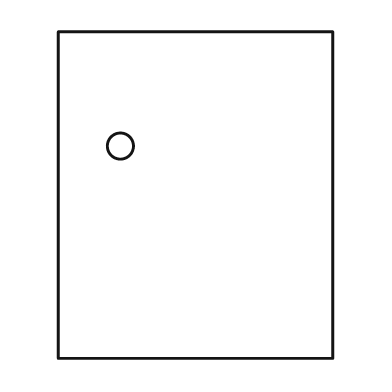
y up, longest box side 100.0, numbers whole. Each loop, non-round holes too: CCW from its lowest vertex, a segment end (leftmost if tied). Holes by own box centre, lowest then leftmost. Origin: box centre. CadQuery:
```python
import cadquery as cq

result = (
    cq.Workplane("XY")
    .moveTo(-42.0, -50.0)
    .lineTo(42.0, -50.0)
    .lineTo(42.0, 50.0)
    .lineTo(-42.0, 50.0)
    .close()
    .moveTo(-23.0, 15.0)
    .circle(4.0)
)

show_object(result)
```